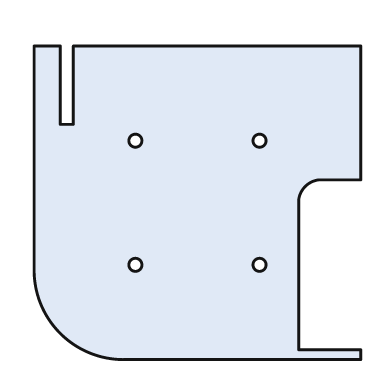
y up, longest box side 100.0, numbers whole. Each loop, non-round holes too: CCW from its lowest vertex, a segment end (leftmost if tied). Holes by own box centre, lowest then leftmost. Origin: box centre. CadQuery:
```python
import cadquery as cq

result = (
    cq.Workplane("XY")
    .moveTo(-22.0, -48.0)
    .lineTo(50.0, -48.0)
    .lineTo(50.0, -45.0)
    .lineTo(31.0, -45.0)
    .lineTo(31.0, 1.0)
    .threePointArc((33.0, 5.0), (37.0, 7.0))
    .lineTo(50.0, 7.0)
    .lineTo(50.0, 48.0)
    .lineTo(-38.0, 48.0)
    .lineTo(-38.0, 24.0)
    .lineTo(-42.0, 24.0)
    .lineTo(-42.0, 48.0)
    .lineTo(-50.0, 48.0)
    .lineTo(-50.0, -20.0)
    .threePointArc((-42.0, -40.0), (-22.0, -48.0))
    .close()
    .moveTo(-19.0, -19.0)
    .circle(2.0)
    .moveTo(19.0, -19.0)
    .circle(2.0)
    .moveTo(-19.0, 19.0)
    .circle(2.0)
    .moveTo(19.0, 19.0)
    .circle(2.0)
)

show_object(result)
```